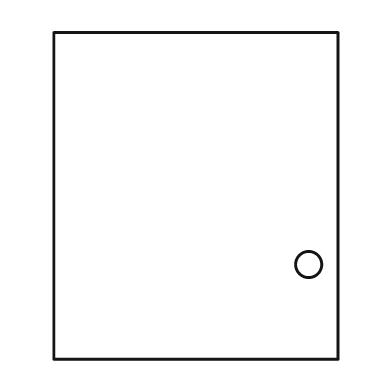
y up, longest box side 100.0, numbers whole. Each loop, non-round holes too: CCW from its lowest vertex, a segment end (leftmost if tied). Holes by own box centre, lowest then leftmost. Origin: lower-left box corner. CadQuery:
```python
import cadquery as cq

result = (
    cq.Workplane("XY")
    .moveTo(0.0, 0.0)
    .lineTo(87.0, 0.0)
    .lineTo(87.0, 100.0)
    .lineTo(0.0, 100.0)
    .close()
    .moveTo(78.0, 29.0)
    .circle(4.0)
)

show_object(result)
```